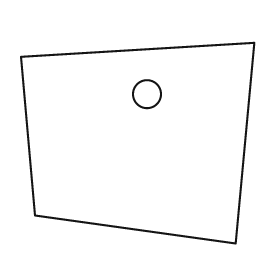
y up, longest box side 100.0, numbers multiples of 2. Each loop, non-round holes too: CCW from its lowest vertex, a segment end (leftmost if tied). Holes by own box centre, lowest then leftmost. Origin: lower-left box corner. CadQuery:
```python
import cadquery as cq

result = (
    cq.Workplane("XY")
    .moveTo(92.0, 0.0)
    .lineTo(100.0, 86.0)
    .lineTo(0.0, 80.0)
    .lineTo(6.0, 12.0)
    .close()
    .moveTo(54.0, 64.0)
    .circle(6.0)
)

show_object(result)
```